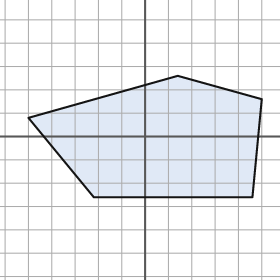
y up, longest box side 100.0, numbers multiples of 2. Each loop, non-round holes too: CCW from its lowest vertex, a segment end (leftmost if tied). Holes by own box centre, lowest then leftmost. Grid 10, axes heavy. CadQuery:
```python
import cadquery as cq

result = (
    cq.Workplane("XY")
    .moveTo(-22.0, -26.0)
    .lineTo(46.0, -26.0)
    .lineTo(50.0, 16.0)
    .lineTo(14.0, 26.0)
    .lineTo(-50.0, 8.0)
    .close()
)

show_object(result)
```